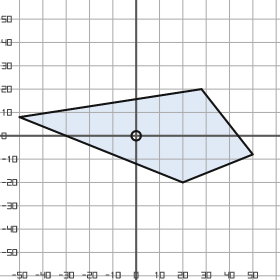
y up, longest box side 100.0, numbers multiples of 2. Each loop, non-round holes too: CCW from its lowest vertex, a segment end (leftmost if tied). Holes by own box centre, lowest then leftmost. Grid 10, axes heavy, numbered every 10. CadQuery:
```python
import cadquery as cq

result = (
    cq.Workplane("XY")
    .moveTo(20.0, -20.0)
    .lineTo(50.0, -8.0)
    .lineTo(28.0, 20.0)
    .lineTo(-50.0, 8.0)
    .close()
    .moveTo(0.0, 0.0)
    .circle(2.0)
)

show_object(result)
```